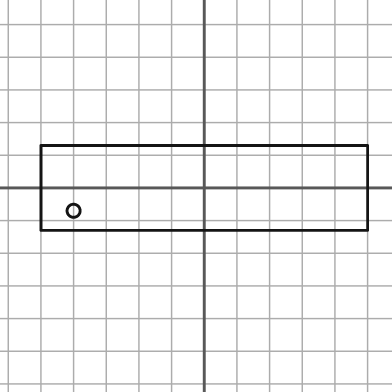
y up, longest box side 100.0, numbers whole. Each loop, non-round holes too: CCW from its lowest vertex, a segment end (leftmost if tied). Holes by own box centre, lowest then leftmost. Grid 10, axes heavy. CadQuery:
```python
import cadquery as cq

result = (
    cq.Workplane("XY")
    .moveTo(-50.0, -13.0)
    .lineTo(50.0, -13.0)
    .lineTo(50.0, 13.0)
    .lineTo(-50.0, 13.0)
    .close()
    .moveTo(-40.0, -7.0)
    .circle(2.0)
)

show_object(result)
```